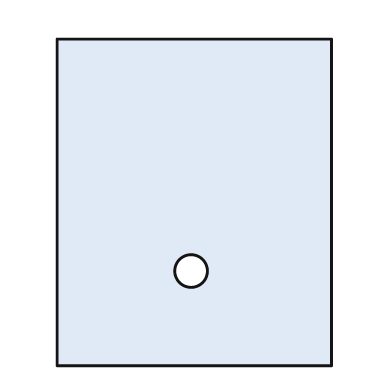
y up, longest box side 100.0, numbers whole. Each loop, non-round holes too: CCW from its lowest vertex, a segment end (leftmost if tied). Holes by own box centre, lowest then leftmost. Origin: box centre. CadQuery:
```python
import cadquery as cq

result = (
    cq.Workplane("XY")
    .moveTo(-42.0, -50.0)
    .lineTo(42.0, -50.0)
    .lineTo(42.0, 50.0)
    .lineTo(-42.0, 50.0)
    .close()
    .moveTo(-1.0, -21.0)
    .circle(5.0)
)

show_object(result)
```